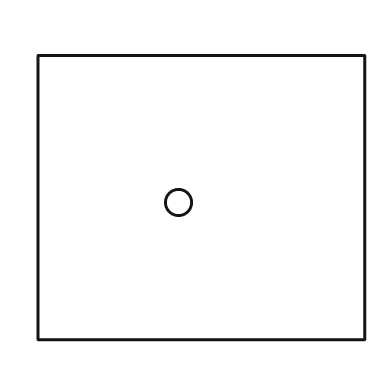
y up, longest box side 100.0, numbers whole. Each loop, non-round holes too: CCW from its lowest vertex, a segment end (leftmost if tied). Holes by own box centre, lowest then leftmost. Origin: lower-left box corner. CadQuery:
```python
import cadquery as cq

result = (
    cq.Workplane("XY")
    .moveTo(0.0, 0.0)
    .lineTo(100.0, 0.0)
    .lineTo(100.0, 87.0)
    .lineTo(0.0, 87.0)
    .close()
    .moveTo(43.0, 42.0)
    .circle(4.0)
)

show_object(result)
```